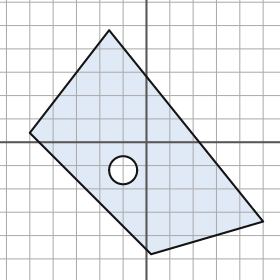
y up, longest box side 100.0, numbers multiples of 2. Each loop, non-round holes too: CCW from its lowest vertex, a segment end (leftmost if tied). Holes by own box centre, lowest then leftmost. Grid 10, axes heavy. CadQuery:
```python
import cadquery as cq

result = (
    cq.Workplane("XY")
    .moveTo(2.0, -48.0)
    .lineTo(50.0, -34.0)
    .lineTo(-16.0, 48.0)
    .lineTo(-50.0, 4.0)
    .close()
    .moveTo(-10.0, -12.0)
    .circle(6.0)
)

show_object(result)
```